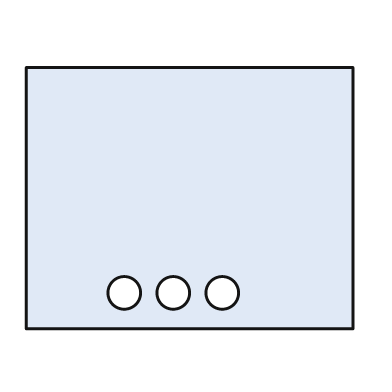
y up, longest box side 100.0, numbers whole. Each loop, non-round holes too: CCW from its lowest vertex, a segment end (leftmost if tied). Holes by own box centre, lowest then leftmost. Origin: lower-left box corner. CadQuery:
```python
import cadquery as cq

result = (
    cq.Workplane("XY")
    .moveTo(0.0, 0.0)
    .lineTo(100.0, 0.0)
    .lineTo(100.0, 80.0)
    .lineTo(0.0, 80.0)
    .close()
    .moveTo(30.0, 11.0)
    .circle(5.0)
    .moveTo(45.0, 11.0)
    .circle(5.0)
    .moveTo(60.0, 11.0)
    .circle(5.0)
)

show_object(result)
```